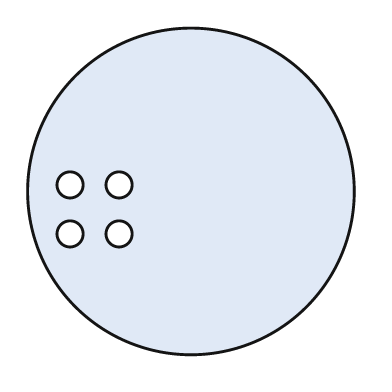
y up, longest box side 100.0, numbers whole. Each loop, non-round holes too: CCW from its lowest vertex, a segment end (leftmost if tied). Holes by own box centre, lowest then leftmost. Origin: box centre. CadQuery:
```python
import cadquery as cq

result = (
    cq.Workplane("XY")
    .moveTo(0.0, 0.0)
    .circle(50.0)
    .moveTo(-37.0, -13.0)
    .circle(4.0)
    .moveTo(-22.0, -13.0)
    .circle(4.0)
    .moveTo(-37.0, 2.0)
    .circle(4.0)
    .moveTo(-22.0, 2.0)
    .circle(4.0)
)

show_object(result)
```